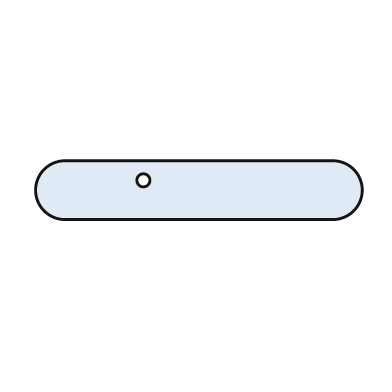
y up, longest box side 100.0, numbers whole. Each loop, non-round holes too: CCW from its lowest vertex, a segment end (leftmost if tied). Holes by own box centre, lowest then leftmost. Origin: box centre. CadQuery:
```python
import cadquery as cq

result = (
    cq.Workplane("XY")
    .moveTo(-41.0, -9.0)
    .lineTo(41.0, -9.0)
    .threePointArc((50.0, 0.0), (41.0, 9.0))
    .lineTo(-41.0, 9.0)
    .threePointArc((-50.0, 0.0), (-41.0, -9.0))
    .close()
    .moveTo(-17.0, 3.0)
    .circle(2.0)
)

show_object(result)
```